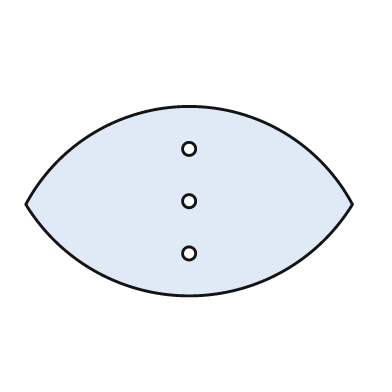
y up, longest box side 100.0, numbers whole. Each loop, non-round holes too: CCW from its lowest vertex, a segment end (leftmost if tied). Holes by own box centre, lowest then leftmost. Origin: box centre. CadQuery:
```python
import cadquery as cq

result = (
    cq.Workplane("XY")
    .moveTo(-50.0, -1.0)
    .threePointArc((0.0, -29.0), (50.0, -1.0))
    .threePointArc((0.0, 29.0), (-50.0, -1.0))
    .close()
    .moveTo(0.0, -16.0)
    .circle(2.0)
    .moveTo(0.0, 0.0)
    .circle(2.0)
    .moveTo(0.0, 16.0)
    .circle(2.0)
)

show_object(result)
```